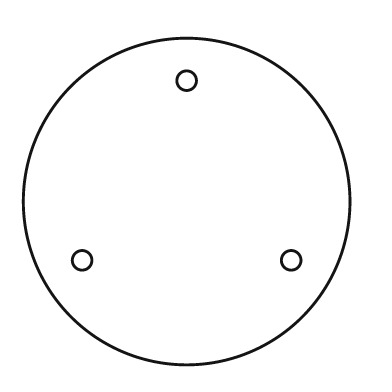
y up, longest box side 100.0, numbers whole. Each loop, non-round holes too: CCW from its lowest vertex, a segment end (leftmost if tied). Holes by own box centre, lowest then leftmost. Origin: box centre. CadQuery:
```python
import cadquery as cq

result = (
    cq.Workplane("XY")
    .moveTo(0.0, 0.0)
    .circle(50.0)
    .moveTo(-32.0, -18.0)
    .circle(3.0)
    .moveTo(32.0, -18.0)
    .circle(3.0)
    .moveTo(0.0, 37.0)
    .circle(3.0)
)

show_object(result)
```